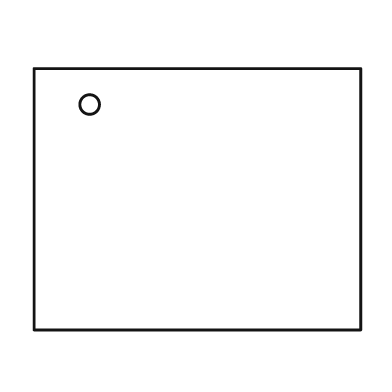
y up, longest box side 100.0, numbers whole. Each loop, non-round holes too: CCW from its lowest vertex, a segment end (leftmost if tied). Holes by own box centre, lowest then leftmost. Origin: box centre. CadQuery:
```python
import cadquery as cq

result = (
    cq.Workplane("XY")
    .moveTo(-50.0, -40.0)
    .lineTo(50.0, -40.0)
    .lineTo(50.0, 40.0)
    .lineTo(-50.0, 40.0)
    .close()
    .moveTo(-33.0, 29.0)
    .circle(3.0)
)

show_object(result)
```